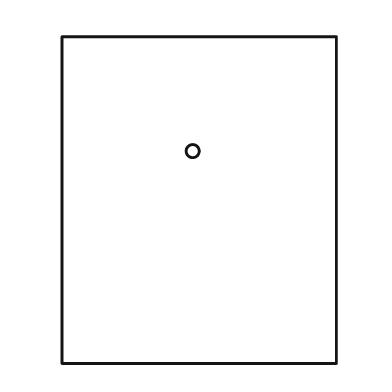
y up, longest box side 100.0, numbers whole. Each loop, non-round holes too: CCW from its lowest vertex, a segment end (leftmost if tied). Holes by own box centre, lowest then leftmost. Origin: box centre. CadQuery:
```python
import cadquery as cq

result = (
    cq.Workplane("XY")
    .moveTo(-42.0, -50.0)
    .lineTo(42.0, -50.0)
    .lineTo(42.0, 50.0)
    .lineTo(-42.0, 50.0)
    .close()
    .moveTo(-2.0, 15.0)
    .circle(2.0)
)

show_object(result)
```